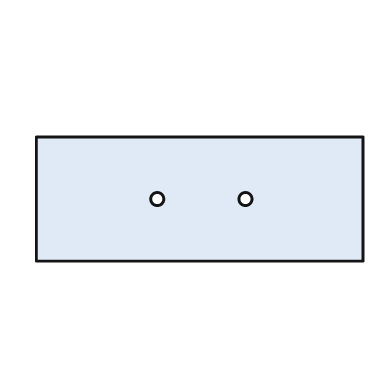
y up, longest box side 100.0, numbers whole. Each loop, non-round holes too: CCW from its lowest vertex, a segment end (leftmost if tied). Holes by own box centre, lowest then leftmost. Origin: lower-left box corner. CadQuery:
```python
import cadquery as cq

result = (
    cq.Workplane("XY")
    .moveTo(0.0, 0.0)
    .lineTo(100.0, 0.0)
    .lineTo(100.0, 38.0)
    .lineTo(0.0, 38.0)
    .close()
    .moveTo(37.0, 19.0)
    .circle(2.0)
    .moveTo(64.0, 19.0)
    .circle(2.0)
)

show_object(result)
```